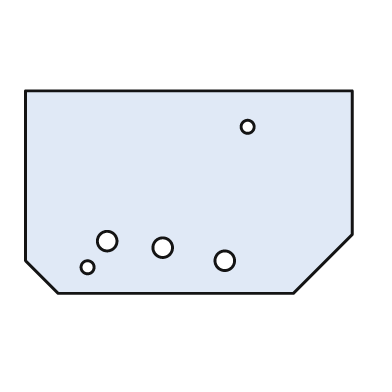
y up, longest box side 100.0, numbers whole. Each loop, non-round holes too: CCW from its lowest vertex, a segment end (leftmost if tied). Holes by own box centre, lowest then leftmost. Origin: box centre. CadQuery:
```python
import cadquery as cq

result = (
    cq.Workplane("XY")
    .moveTo(-40.0, -31.0)
    .lineTo(32.0, -31.0)
    .lineTo(50.0, -13.0)
    .lineTo(50.0, 31.0)
    .lineTo(-50.0, 31.0)
    .lineTo(-50.0, -21.0)
    .close()
    .moveTo(-31.0, -23.0)
    .circle(2.0)
    .moveTo(11.0, -21.0)
    .circle(3.0)
    .moveTo(-8.0, -17.0)
    .circle(3.0)
    .moveTo(-25.0, -15.0)
    .circle(3.0)
    .moveTo(18.0, 20.0)
    .circle(2.0)
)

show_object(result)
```